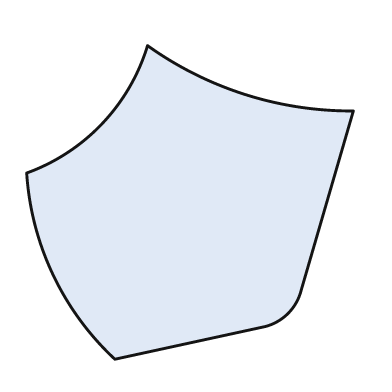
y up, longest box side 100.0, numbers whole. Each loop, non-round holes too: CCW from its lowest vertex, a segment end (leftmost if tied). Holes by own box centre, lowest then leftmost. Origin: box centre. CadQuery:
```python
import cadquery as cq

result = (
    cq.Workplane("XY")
    .moveTo(-23.0, -48.0)
    .lineTo(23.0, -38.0)
    .threePointArc((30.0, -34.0), (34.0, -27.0))
    .lineTo(50.0, 28.0)
    .threePointArc((17.0, 33.0), (-13.0, 48.0))
    .threePointArc((-27.0, 24.0), (-50.0, 9.0))
    .threePointArc((-42.0, -22.0), (-23.0, -48.0))
    .close()
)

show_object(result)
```